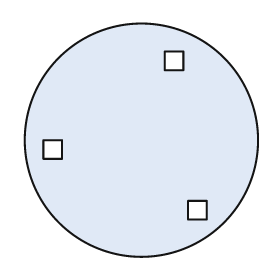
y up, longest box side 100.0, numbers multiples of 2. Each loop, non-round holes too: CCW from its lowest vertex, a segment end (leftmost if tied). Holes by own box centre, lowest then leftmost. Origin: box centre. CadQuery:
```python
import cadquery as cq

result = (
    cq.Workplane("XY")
    .moveTo(0.0, 0.0)
    .circle(50.0)
    .moveTo(20.0, -34.0)
    .lineTo(28.0, -34.0)
    .lineTo(28.0, -26.0)
    .lineTo(20.0, -26.0)
    .close()
    .moveTo(-42.0, -8.0)
    .lineTo(-34.0, -8.0)
    .lineTo(-34.0, 0.0)
    .lineTo(-42.0, 0.0)
    .close()
    .moveTo(10.0, 30.0)
    .lineTo(18.0, 30.0)
    .lineTo(18.0, 38.0)
    .lineTo(10.0, 38.0)
    .close()
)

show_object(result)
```